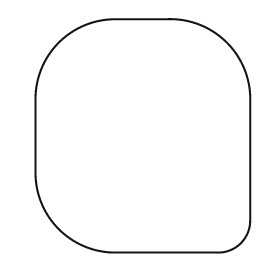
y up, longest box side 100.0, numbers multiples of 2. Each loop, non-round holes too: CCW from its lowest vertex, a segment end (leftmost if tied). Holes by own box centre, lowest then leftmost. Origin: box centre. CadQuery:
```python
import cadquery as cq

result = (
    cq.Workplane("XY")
    .moveTo(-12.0, -50.0)
    .lineTo(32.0, -50.0)
    .threePointArc((42.0, -46.0), (46.0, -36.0))
    .lineTo(46.0, 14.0)
    .threePointArc((36.0, 40.0), (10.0, 50.0))
    .lineTo(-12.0, 50.0)
    .threePointArc((-36.0, 40.0), (-46.0, 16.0))
    .lineTo(-46.0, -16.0)
    .threePointArc((-36.0, -40.0), (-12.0, -50.0))
    .close()
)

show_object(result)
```